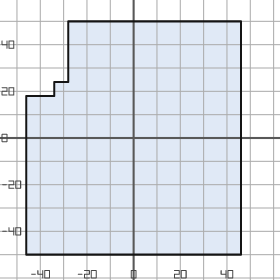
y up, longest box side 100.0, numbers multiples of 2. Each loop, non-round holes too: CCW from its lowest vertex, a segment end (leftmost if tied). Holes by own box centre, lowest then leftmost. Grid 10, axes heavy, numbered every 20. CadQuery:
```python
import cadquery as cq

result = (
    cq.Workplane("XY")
    .moveTo(-46.0, -50.0)
    .lineTo(46.0, -50.0)
    .lineTo(46.0, 50.0)
    .lineTo(-28.0, 50.0)
    .lineTo(-28.0, 24.0)
    .lineTo(-34.0, 24.0)
    .lineTo(-34.0, 18.0)
    .lineTo(-46.0, 18.0)
    .close()
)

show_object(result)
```